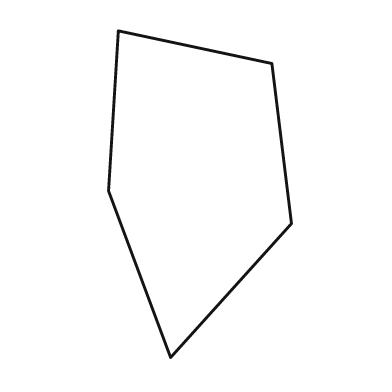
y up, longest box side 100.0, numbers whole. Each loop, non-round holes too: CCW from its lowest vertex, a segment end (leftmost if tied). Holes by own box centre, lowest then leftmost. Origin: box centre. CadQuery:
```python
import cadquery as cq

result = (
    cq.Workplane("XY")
    .moveTo(-9.0, -50.0)
    .lineTo(28.0, -9.0)
    .lineTo(22.0, 40.0)
    .lineTo(-25.0, 50.0)
    .lineTo(-28.0, 1.0)
    .close()
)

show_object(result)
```